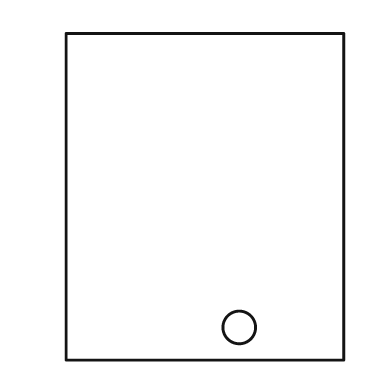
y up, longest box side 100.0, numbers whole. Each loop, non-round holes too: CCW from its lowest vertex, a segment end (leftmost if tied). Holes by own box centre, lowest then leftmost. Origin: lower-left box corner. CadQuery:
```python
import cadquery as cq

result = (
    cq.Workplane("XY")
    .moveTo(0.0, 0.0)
    .lineTo(85.0, 0.0)
    .lineTo(85.0, 100.0)
    .lineTo(0.0, 100.0)
    .close()
    .moveTo(53.0, 10.0)
    .circle(5.0)
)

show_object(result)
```